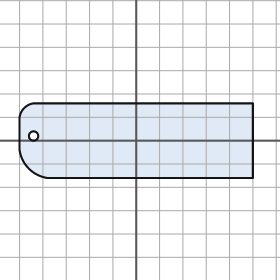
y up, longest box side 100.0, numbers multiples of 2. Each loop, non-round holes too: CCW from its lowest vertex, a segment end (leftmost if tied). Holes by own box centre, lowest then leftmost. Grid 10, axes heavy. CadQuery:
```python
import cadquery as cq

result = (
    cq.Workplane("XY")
    .moveTo(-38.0, -16.0)
    .lineTo(50.0, -16.0)
    .lineTo(50.0, 16.0)
    .lineTo(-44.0, 16.0)
    .threePointArc((-48.0, 14.0), (-50.0, 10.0))
    .lineTo(-50.0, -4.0)
    .threePointArc((-46.0, -12.0), (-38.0, -16.0))
    .close()
    .moveTo(-44.0, 2.0)
    .circle(2.0)
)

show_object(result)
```